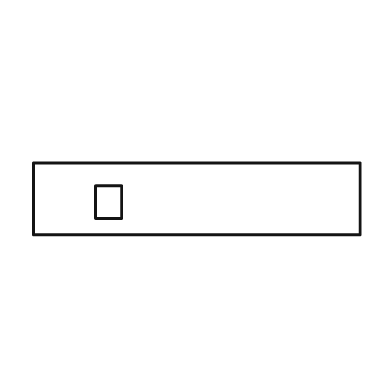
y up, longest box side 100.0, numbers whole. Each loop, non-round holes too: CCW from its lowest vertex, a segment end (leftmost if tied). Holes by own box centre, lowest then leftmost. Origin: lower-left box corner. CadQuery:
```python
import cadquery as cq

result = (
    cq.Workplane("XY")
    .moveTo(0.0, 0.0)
    .lineTo(100.0, 0.0)
    .lineTo(100.0, 22.0)
    .lineTo(0.0, 22.0)
    .close()
    .moveTo(19.0, 5.0)
    .lineTo(27.0, 5.0)
    .lineTo(27.0, 15.0)
    .lineTo(19.0, 15.0)
    .close()
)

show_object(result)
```